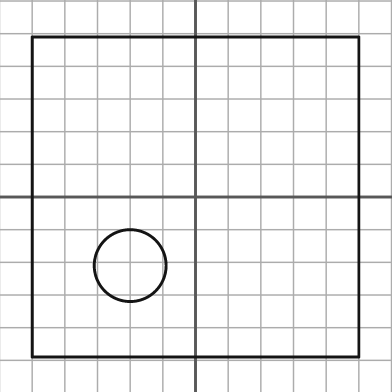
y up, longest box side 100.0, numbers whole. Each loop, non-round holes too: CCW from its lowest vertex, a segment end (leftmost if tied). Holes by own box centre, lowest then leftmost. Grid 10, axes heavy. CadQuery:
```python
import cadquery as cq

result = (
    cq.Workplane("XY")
    .moveTo(-50.0, -49.0)
    .lineTo(50.0, -49.0)
    .lineTo(50.0, 49.0)
    .lineTo(-50.0, 49.0)
    .close()
    .moveTo(-20.0, -21.0)
    .circle(11.0)
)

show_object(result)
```